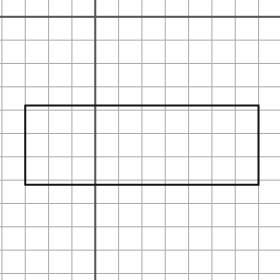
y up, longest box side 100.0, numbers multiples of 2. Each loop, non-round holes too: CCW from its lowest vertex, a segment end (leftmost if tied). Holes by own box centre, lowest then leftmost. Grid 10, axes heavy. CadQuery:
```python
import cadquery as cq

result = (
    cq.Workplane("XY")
    .moveTo(-30.0, -72.0)
    .lineTo(70.0, -72.0)
    .lineTo(70.0, -38.0)
    .lineTo(-30.0, -38.0)
    .close()
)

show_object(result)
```